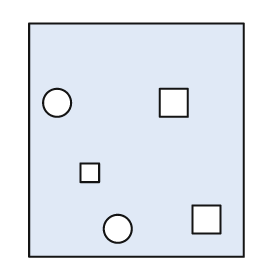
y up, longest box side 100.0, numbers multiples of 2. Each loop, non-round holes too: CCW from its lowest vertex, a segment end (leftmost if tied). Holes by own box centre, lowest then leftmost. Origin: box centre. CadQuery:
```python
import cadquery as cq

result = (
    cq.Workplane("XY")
    .moveTo(-46.0, -50.0)
    .lineTo(46.0, -50.0)
    .lineTo(46.0, 50.0)
    .lineTo(-46.0, 50.0)
    .close()
    .moveTo(-8.0, -38.0)
    .circle(6.0)
    .moveTo(24.0, -40.0)
    .lineTo(36.0, -40.0)
    .lineTo(36.0, -28.0)
    .lineTo(24.0, -28.0)
    .close()
    .moveTo(-24.0, -18.0)
    .lineTo(-16.0, -18.0)
    .lineTo(-16.0, -10.0)
    .lineTo(-24.0, -10.0)
    .close()
    .moveTo(-34.0, 16.0)
    .circle(6.0)
    .moveTo(10.0, 10.0)
    .lineTo(22.0, 10.0)
    .lineTo(22.0, 22.0)
    .lineTo(10.0, 22.0)
    .close()
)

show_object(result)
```